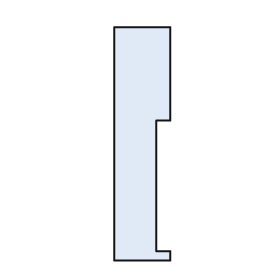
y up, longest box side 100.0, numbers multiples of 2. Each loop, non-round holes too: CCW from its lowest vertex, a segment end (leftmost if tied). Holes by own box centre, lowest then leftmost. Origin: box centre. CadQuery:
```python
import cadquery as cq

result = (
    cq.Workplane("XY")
    .moveTo(-12.0, -50.0)
    .lineTo(12.0, -50.0)
    .lineTo(12.0, -46.0)
    .lineTo(6.0, -46.0)
    .lineTo(6.0, 10.0)
    .lineTo(12.0, 10.0)
    .lineTo(12.0, 50.0)
    .lineTo(-12.0, 50.0)
    .close()
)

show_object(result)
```